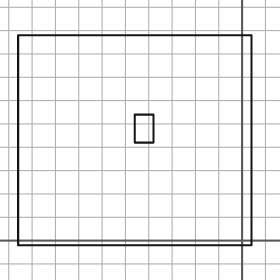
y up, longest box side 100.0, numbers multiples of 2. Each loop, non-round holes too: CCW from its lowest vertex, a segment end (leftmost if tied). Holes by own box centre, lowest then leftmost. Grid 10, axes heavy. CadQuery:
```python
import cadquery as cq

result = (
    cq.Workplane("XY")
    .moveTo(-96.0, -2.0)
    .lineTo(4.0, -2.0)
    .lineTo(4.0, 88.0)
    .lineTo(-96.0, 88.0)
    .close()
    .moveTo(-46.0, 42.0)
    .lineTo(-38.0, 42.0)
    .lineTo(-38.0, 54.0)
    .lineTo(-46.0, 54.0)
    .close()
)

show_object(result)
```